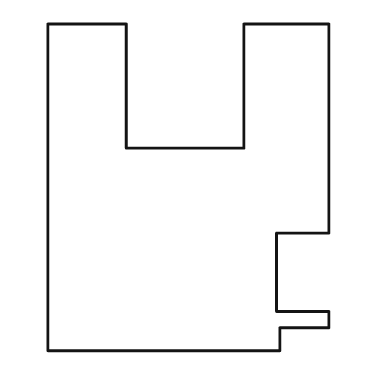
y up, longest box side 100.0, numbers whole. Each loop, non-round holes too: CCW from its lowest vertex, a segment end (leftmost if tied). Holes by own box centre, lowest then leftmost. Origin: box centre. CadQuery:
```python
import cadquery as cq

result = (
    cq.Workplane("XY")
    .moveTo(-43.0, -50.0)
    .lineTo(28.0, -50.0)
    .lineTo(28.0, -43.0)
    .lineTo(43.0, -43.0)
    .lineTo(43.0, -38.0)
    .lineTo(27.0, -38.0)
    .lineTo(27.0, -14.0)
    .lineTo(43.0, -14.0)
    .lineTo(43.0, 50.0)
    .lineTo(17.0, 50.0)
    .lineTo(17.0, 12.0)
    .lineTo(-19.0, 12.0)
    .lineTo(-19.0, 50.0)
    .lineTo(-43.0, 50.0)
    .close()
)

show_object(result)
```